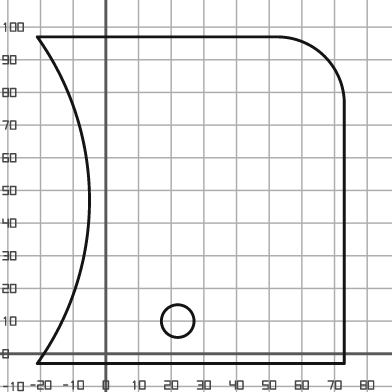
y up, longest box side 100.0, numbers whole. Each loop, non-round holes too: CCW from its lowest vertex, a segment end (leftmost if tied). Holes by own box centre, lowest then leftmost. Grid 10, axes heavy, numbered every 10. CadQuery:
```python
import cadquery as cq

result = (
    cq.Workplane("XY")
    .moveTo(-21.0, -3.0)
    .lineTo(73.0, -3.0)
    .lineTo(73.0, 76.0)
    .threePointArc((67.0, 91.0), (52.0, 97.0))
    .lineTo(-21.0, 97.0)
    .threePointArc((-5.0, 47.0), (-21.0, -3.0))
    .close()
    .moveTo(22.0, 10.0)
    .circle(5.0)
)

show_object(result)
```